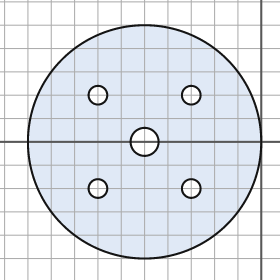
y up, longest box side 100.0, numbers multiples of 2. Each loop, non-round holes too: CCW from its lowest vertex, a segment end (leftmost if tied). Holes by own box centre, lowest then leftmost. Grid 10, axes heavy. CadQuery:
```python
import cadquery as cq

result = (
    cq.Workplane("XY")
    .moveTo(-50.0, 0.0)
    .circle(50.0)
    .moveTo(-70.0, -20.0)
    .circle(4.0)
    .moveTo(-30.0, -20.0)
    .circle(4.0)
    .moveTo(-50.0, 0.0)
    .circle(6.0)
    .moveTo(-70.0, 20.0)
    .circle(4.0)
    .moveTo(-30.0, 20.0)
    .circle(4.0)
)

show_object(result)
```